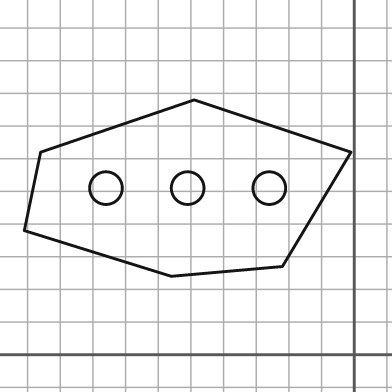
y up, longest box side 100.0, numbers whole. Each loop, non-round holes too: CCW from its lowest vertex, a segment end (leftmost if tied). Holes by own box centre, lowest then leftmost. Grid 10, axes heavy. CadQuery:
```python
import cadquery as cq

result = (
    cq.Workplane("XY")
    .moveTo(-56.0, 24.0)
    .lineTo(-22.0, 27.0)
    .lineTo(-1.0, 62.0)
    .lineTo(-49.0, 78.0)
    .lineTo(-96.0, 62.0)
    .lineTo(-101.0, 38.0)
    .close()
    .moveTo(-76.0, 51.0)
    .circle(5.0)
    .moveTo(-51.0, 51.0)
    .circle(5.0)
    .moveTo(-26.0, 51.0)
    .circle(5.0)
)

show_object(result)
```